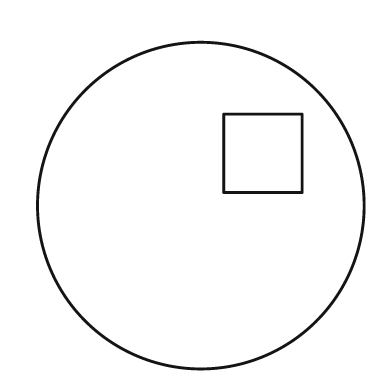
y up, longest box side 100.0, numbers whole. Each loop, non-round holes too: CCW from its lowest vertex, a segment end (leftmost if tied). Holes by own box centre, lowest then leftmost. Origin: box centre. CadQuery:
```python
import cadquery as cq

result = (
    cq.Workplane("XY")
    .moveTo(0.0, 0.0)
    .circle(50.0)
    .moveTo(7.0, 4.0)
    .lineTo(31.0, 4.0)
    .lineTo(31.0, 28.0)
    .lineTo(7.0, 28.0)
    .close()
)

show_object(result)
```